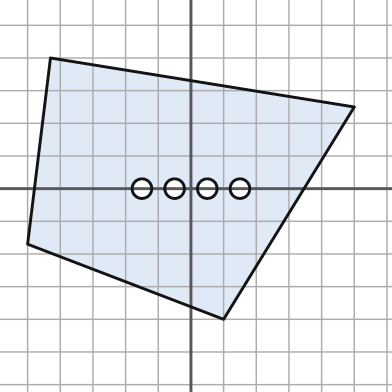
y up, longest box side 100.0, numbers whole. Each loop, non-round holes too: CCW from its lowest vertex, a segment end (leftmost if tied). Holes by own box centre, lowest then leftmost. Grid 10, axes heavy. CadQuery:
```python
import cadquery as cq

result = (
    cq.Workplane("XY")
    .moveTo(10.0, -40.0)
    .lineTo(50.0, 25.0)
    .lineTo(-43.0, 40.0)
    .lineTo(-50.0, -17.0)
    .close()
    .moveTo(-15.0, 0.0)
    .circle(3.0)
    .moveTo(-5.0, 0.0)
    .circle(3.0)
    .moveTo(5.0, 0.0)
    .circle(3.0)
    .moveTo(15.0, 0.0)
    .circle(3.0)
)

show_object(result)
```